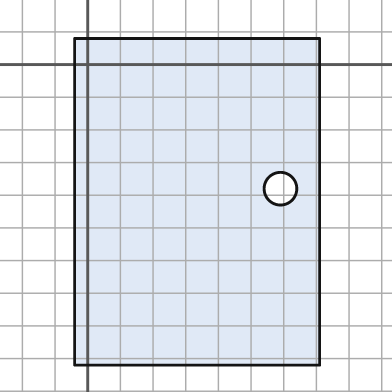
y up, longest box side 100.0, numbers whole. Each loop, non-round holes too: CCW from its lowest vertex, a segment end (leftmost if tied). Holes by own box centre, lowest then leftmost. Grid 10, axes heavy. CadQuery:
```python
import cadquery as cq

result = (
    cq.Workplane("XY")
    .moveTo(-4.0, -92.0)
    .lineTo(71.0, -92.0)
    .lineTo(71.0, 8.0)
    .lineTo(-4.0, 8.0)
    .close()
    .moveTo(59.0, -38.0)
    .circle(5.0)
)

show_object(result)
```